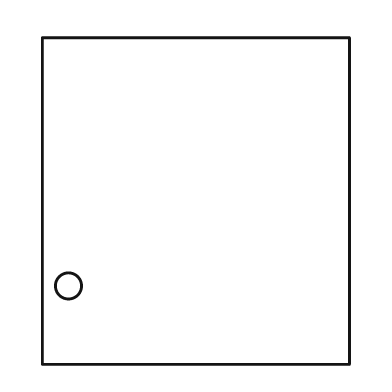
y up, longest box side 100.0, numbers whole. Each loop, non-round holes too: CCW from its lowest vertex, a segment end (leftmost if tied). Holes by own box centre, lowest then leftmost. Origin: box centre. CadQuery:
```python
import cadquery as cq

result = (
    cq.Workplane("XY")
    .moveTo(-47.0, -50.0)
    .lineTo(47.0, -50.0)
    .lineTo(47.0, 50.0)
    .lineTo(-47.0, 50.0)
    .close()
    .moveTo(-39.0, -26.0)
    .circle(4.0)
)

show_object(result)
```